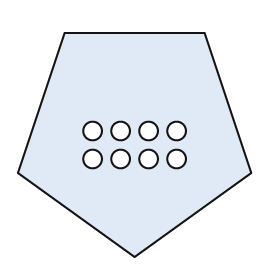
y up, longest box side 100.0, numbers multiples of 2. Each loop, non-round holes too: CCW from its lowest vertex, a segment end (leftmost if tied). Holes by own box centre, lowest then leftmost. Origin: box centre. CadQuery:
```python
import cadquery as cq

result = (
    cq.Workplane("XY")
    .moveTo(0.0, -48.0)
    .lineTo(50.0, -12.0)
    .lineTo(30.0, 48.0)
    .lineTo(-30.0, 48.0)
    .lineTo(-50.0, -12.0)
    .close()
    .moveTo(-18.0, -6.0)
    .circle(4.0)
    .moveTo(-6.0, -6.0)
    .circle(4.0)
    .moveTo(6.0, -6.0)
    .circle(4.0)
    .moveTo(18.0, -6.0)
    .circle(4.0)
    .moveTo(-18.0, 6.0)
    .circle(4.0)
    .moveTo(-6.0, 6.0)
    .circle(4.0)
    .moveTo(6.0, 6.0)
    .circle(4.0)
    .moveTo(18.0, 6.0)
    .circle(4.0)
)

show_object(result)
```